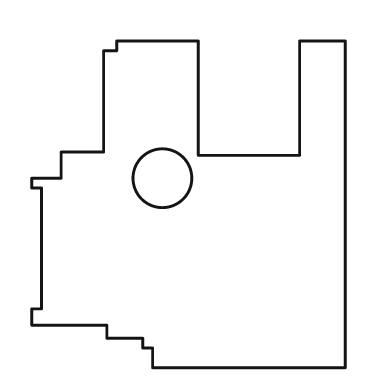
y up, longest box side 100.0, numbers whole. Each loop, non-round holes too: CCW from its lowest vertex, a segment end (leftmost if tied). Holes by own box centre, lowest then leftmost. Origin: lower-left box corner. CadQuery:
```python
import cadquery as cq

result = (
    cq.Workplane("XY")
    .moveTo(37.0, 0.0)
    .lineTo(96.0, 0.0)
    .lineTo(96.0, 100.0)
    .lineTo(82.0, 100.0)
    .lineTo(82.0, 65.0)
    .lineTo(51.0, 65.0)
    .lineTo(51.0, 100.0)
    .lineTo(26.0, 100.0)
    .lineTo(26.0, 97.0)
    .lineTo(22.0, 97.0)
    .lineTo(22.0, 66.0)
    .lineTo(9.0, 66.0)
    .lineTo(9.0, 58.0)
    .lineTo(0.0, 58.0)
    .lineTo(0.0, 55.0)
    .lineTo(3.0, 55.0)
    .lineTo(3.0, 18.0)
    .lineTo(0.0, 18.0)
    .lineTo(0.0, 13.0)
    .lineTo(23.0, 13.0)
    .lineTo(23.0, 9.0)
    .lineTo(34.0, 9.0)
    .lineTo(34.0, 6.0)
    .lineTo(37.0, 6.0)
    .close()
    .moveTo(40.0, 58.0)
    .circle(9.0)
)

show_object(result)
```